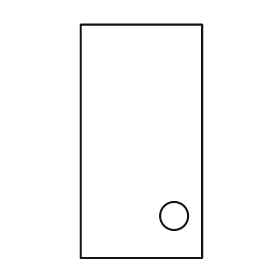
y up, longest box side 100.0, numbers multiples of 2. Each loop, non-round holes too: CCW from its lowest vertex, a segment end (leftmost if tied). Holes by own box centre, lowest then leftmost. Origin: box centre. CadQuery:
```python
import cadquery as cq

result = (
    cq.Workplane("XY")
    .moveTo(-26.0, -50.0)
    .lineTo(26.0, -50.0)
    .lineTo(26.0, 50.0)
    .lineTo(-26.0, 50.0)
    .close()
    .moveTo(14.0, -32.0)
    .circle(6.0)
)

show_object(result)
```